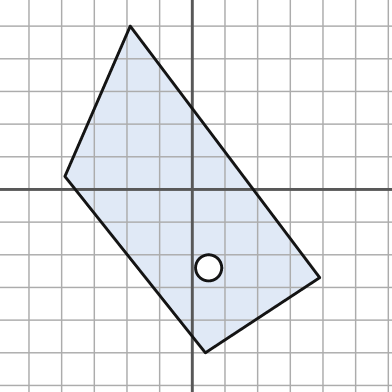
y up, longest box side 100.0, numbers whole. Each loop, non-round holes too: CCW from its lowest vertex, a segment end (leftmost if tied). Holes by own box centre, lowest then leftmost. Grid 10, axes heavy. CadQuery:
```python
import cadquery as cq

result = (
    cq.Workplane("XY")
    .moveTo(4.0, -50.0)
    .lineTo(39.0, -27.0)
    .lineTo(-19.0, 50.0)
    .lineTo(-39.0, 4.0)
    .close()
    .moveTo(5.0, -24.0)
    .circle(4.0)
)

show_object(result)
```